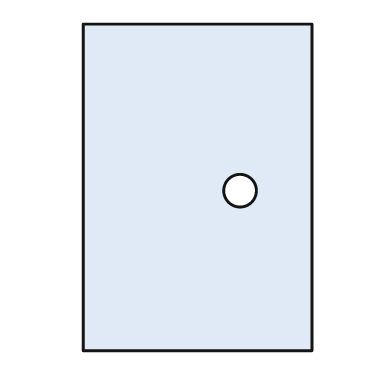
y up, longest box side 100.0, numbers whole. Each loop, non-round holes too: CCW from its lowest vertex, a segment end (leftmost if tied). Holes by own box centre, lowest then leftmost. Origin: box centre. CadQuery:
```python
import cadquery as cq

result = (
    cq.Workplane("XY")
    .moveTo(-35.0, -50.0)
    .lineTo(35.0, -50.0)
    .lineTo(35.0, 50.0)
    .lineTo(-35.0, 50.0)
    .close()
    .moveTo(13.0, -1.0)
    .circle(5.0)
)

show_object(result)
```